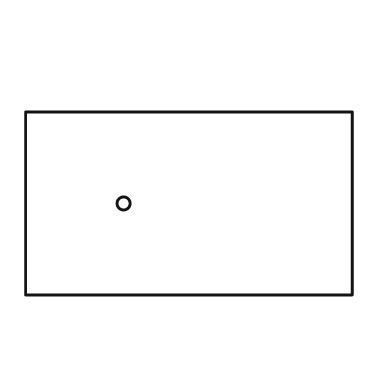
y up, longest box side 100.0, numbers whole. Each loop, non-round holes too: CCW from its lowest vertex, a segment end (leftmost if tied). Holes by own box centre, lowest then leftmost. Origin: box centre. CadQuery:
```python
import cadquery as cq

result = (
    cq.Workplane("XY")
    .moveTo(-50.0, -28.0)
    .lineTo(50.0, -28.0)
    .lineTo(50.0, 28.0)
    .lineTo(-50.0, 28.0)
    .close()
    .moveTo(-20.0, 0.0)
    .circle(2.0)
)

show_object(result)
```